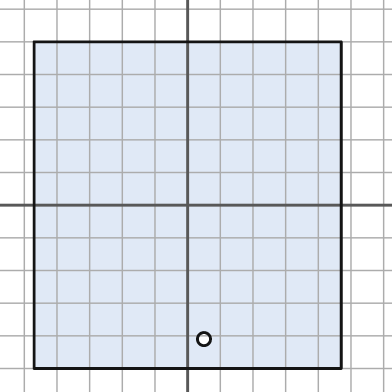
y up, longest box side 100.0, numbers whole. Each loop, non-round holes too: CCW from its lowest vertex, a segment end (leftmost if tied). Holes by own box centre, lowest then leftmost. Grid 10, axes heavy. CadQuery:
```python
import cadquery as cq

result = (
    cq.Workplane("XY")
    .moveTo(-47.0, -50.0)
    .lineTo(47.0, -50.0)
    .lineTo(47.0, 50.0)
    .lineTo(-47.0, 50.0)
    .close()
    .moveTo(5.0, -41.0)
    .circle(2.0)
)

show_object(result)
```